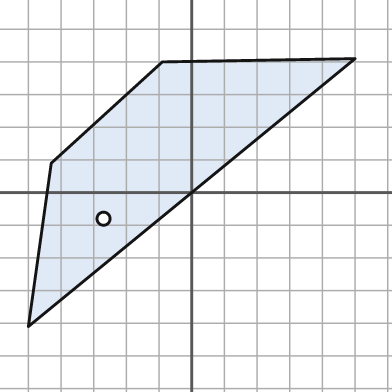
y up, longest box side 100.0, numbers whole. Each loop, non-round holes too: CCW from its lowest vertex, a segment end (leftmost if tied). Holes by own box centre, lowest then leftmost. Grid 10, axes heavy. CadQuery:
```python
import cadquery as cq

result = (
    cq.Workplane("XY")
    .moveTo(-50.0, -41.0)
    .lineTo(50.0, 41.0)
    .lineTo(-9.0, 40.0)
    .lineTo(-43.0, 9.0)
    .close()
    .moveTo(-27.0, -8.0)
    .circle(2.0)
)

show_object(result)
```